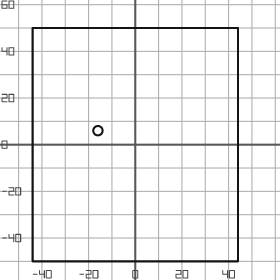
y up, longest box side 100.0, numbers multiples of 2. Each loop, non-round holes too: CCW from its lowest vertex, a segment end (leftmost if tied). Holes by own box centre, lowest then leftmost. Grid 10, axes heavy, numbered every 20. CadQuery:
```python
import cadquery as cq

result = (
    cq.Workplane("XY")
    .moveTo(-44.0, -50.0)
    .lineTo(44.0, -50.0)
    .lineTo(44.0, 50.0)
    .lineTo(-44.0, 50.0)
    .close()
    .moveTo(-16.0, 6.0)
    .circle(2.0)
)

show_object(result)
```